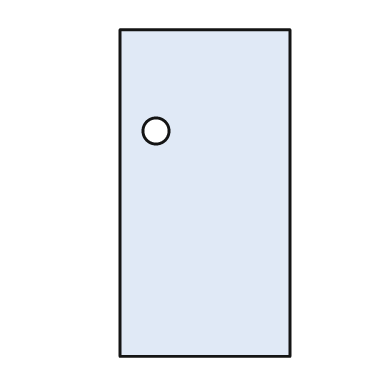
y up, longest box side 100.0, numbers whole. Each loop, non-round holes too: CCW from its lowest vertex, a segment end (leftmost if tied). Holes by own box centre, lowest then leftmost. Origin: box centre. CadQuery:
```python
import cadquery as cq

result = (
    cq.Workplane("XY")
    .moveTo(-26.0, -50.0)
    .lineTo(26.0, -50.0)
    .lineTo(26.0, 50.0)
    .lineTo(-26.0, 50.0)
    .close()
    .moveTo(-15.0, 19.0)
    .circle(4.0)
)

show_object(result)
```